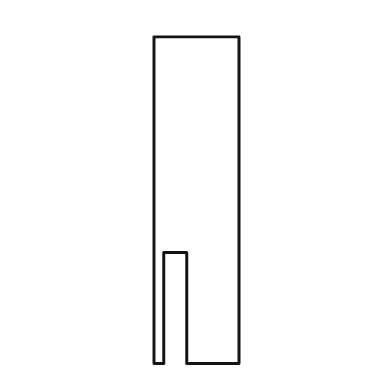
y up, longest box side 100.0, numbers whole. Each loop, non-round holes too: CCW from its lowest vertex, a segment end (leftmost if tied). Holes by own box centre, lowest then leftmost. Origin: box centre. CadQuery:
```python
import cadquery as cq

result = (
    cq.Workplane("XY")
    .moveTo(-13.0, -50.0)
    .lineTo(-10.0, -50.0)
    .lineTo(-10.0, -16.0)
    .lineTo(-3.0, -16.0)
    .lineTo(-3.0, -50.0)
    .lineTo(13.0, -50.0)
    .lineTo(13.0, 50.0)
    .lineTo(-13.0, 50.0)
    .close()
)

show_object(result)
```